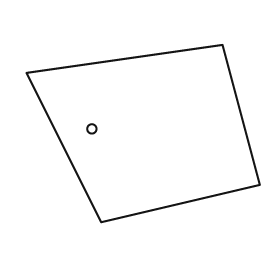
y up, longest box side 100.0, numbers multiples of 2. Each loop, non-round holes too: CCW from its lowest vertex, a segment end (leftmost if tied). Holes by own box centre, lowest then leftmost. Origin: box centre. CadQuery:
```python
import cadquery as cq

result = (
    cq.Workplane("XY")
    .moveTo(-18.0, -38.0)
    .lineTo(50.0, -22.0)
    .lineTo(34.0, 38.0)
    .lineTo(-50.0, 26.0)
    .close()
    .moveTo(-22.0, 2.0)
    .circle(2.0)
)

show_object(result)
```